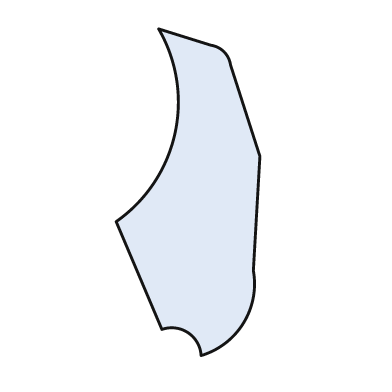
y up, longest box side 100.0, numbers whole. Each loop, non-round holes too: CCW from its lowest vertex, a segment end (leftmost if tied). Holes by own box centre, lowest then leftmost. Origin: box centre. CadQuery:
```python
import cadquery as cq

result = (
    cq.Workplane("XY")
    .moveTo(4.0, -50.0)
    .threePointArc((17.0, -40.0), (20.0, -24.0))
    .lineTo(22.0, 11.0)
    .lineTo(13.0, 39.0)
    .threePointArc((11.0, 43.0), (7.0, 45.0))
    .lineTo(-9.0, 50.0)
    .threePointArc((-4.0, 18.0), (-22.0, -9.0))
    .lineTo(-8.0, -42.0)
    .threePointArc((0.0, -43.0), (4.0, -50.0))
    .close()
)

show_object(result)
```